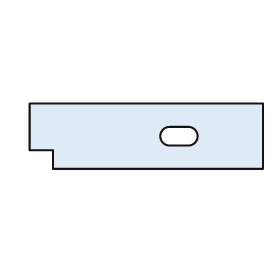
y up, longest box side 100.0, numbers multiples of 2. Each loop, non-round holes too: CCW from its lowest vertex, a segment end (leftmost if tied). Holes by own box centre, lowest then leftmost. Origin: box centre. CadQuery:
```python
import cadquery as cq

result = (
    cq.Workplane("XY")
    .moveTo(-40.0, -14.0)
    .lineTo(50.0, -14.0)
    .lineTo(50.0, 14.0)
    .lineTo(-50.0, 14.0)
    .lineTo(-50.0, -6.0)
    .lineTo(-40.0, -6.0)
    .close()
    .moveTo(10.0, -4.0)
    .lineTo(18.0, -4.0)
    .threePointArc((22.0, 0.0), (18.0, 4.0))
    .lineTo(10.0, 4.0)
    .threePointArc((6.0, 0.0), (10.0, -4.0))
    .close()
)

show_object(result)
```